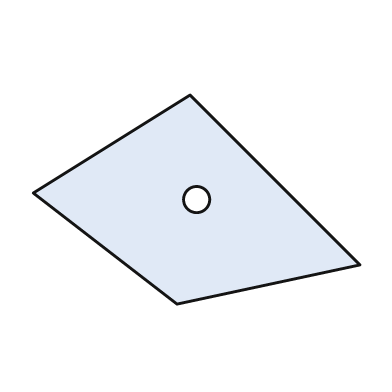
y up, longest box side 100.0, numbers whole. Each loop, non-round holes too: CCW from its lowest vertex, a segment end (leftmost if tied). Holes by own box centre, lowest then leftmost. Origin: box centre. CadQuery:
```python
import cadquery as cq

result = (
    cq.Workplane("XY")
    .moveTo(-6.0, -32.0)
    .lineTo(50.0, -20.0)
    .lineTo(-2.0, 32.0)
    .lineTo(-50.0, 2.0)
    .close()
    .moveTo(0.0, 0.0)
    .circle(4.0)
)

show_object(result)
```